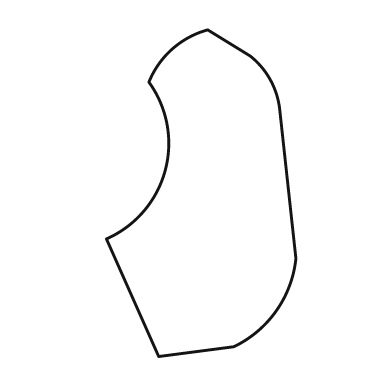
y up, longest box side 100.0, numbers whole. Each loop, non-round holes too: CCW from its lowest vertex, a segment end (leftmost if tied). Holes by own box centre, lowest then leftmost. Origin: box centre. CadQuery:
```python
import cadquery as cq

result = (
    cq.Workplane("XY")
    .moveTo(-13.0, -50.0)
    .lineTo(10.0, -47.0)
    .threePointArc((23.0, -36.0), (29.0, -20.0))
    .lineTo(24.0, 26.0)
    .threePointArc((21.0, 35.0), (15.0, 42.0))
    .lineTo(2.0, 50.0)
    .threePointArc((-9.0, 44.0), (-16.0, 34.0))
    .threePointArc((-11.0, 7.0), (-29.0, -14.0))
    .close()
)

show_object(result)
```